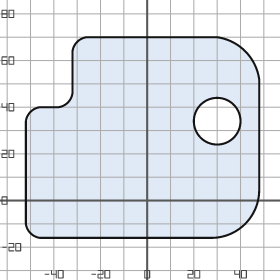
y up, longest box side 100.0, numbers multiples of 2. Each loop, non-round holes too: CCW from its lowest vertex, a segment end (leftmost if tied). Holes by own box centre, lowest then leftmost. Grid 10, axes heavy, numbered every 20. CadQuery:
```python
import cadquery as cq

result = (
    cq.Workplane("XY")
    .moveTo(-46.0, -16.0)
    .lineTo(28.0, -16.0)
    .threePointArc((42.0, -10.0), (48.0, 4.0))
    .lineTo(48.0, 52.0)
    .threePointArc((42.0, 64.0), (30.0, 70.0))
    .lineTo(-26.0, 70.0)
    .threePointArc((-30.0, 68.0), (-32.0, 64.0))
    .lineTo(-32.0, 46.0)
    .threePointArc((-34.0, 42.0), (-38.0, 40.0))
    .lineTo(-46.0, 40.0)
    .threePointArc((-50.0, 38.0), (-52.0, 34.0))
    .lineTo(-52.0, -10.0)
    .threePointArc((-50.0, -14.0), (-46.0, -16.0))
    .close()
    .moveTo(30.0, 34.0)
    .circle(10.0)
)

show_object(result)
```